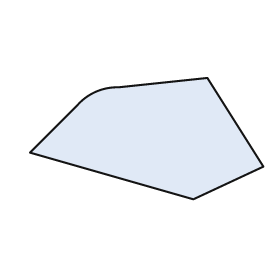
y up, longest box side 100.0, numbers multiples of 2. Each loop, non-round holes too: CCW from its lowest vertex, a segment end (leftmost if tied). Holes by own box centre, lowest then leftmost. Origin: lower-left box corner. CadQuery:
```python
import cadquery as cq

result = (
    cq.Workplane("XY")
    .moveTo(70.0, 0.0)
    .lineTo(100.0, 14.0)
    .lineTo(76.0, 52.0)
    .lineTo(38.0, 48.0)
    .threePointArc((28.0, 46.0), (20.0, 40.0))
    .lineTo(0.0, 20.0)
    .close()
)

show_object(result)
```